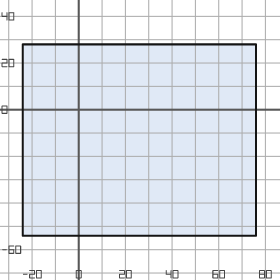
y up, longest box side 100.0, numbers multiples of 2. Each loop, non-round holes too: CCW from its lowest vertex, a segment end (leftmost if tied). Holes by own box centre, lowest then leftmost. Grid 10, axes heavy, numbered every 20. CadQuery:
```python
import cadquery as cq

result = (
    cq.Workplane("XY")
    .moveTo(-24.0, -54.0)
    .lineTo(76.0, -54.0)
    .lineTo(76.0, 28.0)
    .lineTo(-24.0, 28.0)
    .close()
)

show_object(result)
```